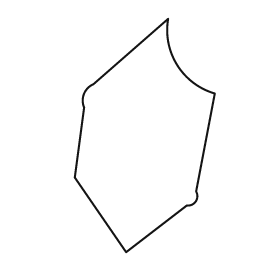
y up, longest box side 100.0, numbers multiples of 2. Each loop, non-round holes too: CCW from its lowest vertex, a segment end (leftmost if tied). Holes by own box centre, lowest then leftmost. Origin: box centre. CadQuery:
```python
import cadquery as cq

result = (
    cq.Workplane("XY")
    .moveTo(-8.0, -50.0)
    .lineTo(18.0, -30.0)
    .threePointArc((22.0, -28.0), (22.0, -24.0))
    .lineTo(30.0, 18.0)
    .threePointArc((14.0, 30.0), (10.0, 50.0))
    .lineTo(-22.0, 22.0)
    .threePointArc((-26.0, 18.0), (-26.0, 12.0))
    .lineTo(-30.0, -18.0)
    .close()
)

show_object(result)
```